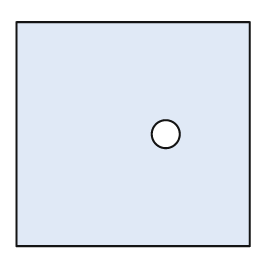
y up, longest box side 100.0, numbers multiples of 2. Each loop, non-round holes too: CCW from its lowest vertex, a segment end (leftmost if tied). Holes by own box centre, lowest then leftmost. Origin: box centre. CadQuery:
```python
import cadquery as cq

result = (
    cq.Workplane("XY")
    .moveTo(-50.0, -48.0)
    .lineTo(50.0, -48.0)
    .lineTo(50.0, 48.0)
    .lineTo(-50.0, 48.0)
    .close()
    .moveTo(14.0, 0.0)
    .circle(6.0)
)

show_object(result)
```